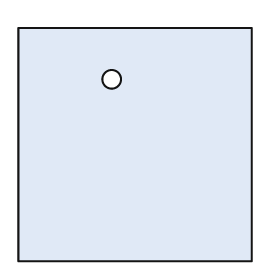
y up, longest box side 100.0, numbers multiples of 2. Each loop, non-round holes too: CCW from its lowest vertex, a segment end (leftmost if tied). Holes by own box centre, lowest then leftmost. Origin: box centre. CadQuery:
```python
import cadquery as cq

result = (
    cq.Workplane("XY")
    .moveTo(-50.0, -50.0)
    .lineTo(50.0, -50.0)
    .lineTo(50.0, 50.0)
    .lineTo(-50.0, 50.0)
    .close()
    .moveTo(-10.0, 28.0)
    .circle(4.0)
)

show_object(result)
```